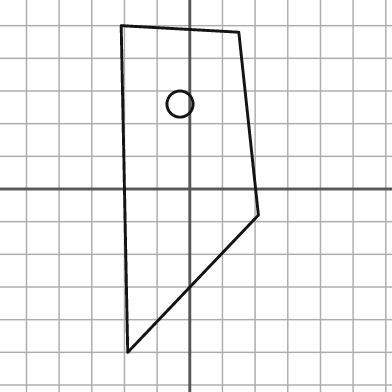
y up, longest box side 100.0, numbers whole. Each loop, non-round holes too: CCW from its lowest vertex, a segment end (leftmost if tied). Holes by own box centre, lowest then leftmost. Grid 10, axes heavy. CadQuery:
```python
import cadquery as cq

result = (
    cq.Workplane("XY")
    .moveTo(-19.0, -50.0)
    .lineTo(21.0, -8.0)
    .lineTo(15.0, 48.0)
    .lineTo(-21.0, 50.0)
    .close()
    .moveTo(-3.0, 26.0)
    .circle(4.0)
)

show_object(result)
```